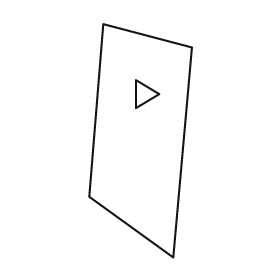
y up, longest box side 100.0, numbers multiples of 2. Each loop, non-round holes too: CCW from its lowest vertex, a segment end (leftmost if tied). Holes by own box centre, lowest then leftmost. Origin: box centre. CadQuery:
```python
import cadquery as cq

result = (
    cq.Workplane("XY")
    .moveTo(14.0, -50.0)
    .lineTo(22.0, 40.0)
    .lineTo(-16.0, 50.0)
    .lineTo(-22.0, -24.0)
    .close()
    .moveTo(-2.0, 14.0)
    .lineTo(8.0, 20.0)
    .lineTo(-2.0, 26.0)
    .close()
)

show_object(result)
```